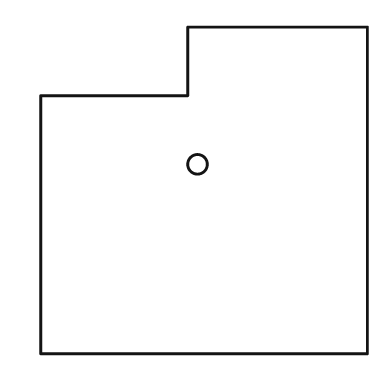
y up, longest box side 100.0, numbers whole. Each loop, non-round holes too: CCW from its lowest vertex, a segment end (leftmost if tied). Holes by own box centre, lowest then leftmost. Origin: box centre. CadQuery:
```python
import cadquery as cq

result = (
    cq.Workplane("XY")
    .moveTo(-50.0, -50.0)
    .lineTo(50.0, -50.0)
    .lineTo(50.0, 50.0)
    .lineTo(-5.0, 50.0)
    .lineTo(-5.0, 29.0)
    .lineTo(-50.0, 29.0)
    .close()
    .moveTo(-2.0, 8.0)
    .circle(3.0)
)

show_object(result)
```